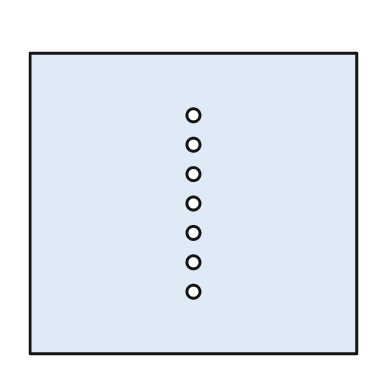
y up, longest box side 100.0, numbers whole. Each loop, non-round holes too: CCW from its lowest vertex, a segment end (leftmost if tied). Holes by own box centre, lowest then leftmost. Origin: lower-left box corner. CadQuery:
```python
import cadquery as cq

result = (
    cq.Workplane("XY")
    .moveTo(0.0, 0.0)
    .lineTo(100.0, 0.0)
    .lineTo(100.0, 92.0)
    .lineTo(0.0, 92.0)
    .close()
    .moveTo(50.0, 19.0)
    .circle(2.0)
    .moveTo(50.0, 28.0)
    .circle(2.0)
    .moveTo(50.0, 37.0)
    .circle(2.0)
    .moveTo(50.0, 46.0)
    .circle(2.0)
    .moveTo(50.0, 55.0)
    .circle(2.0)
    .moveTo(50.0, 64.0)
    .circle(2.0)
    .moveTo(50.0, 73.0)
    .circle(2.0)
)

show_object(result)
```